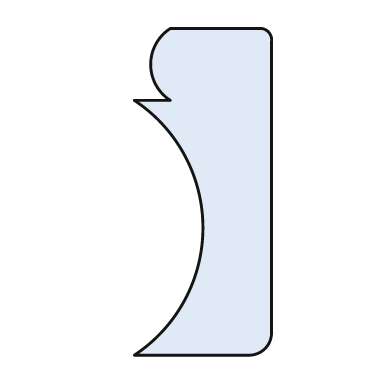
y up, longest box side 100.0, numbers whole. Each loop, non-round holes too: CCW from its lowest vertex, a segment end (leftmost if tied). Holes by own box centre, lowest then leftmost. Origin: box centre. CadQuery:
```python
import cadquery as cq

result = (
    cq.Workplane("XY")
    .moveTo(-21.0, -50.0)
    .lineTo(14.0, -50.0)
    .threePointArc((19.0, -48.0), (21.0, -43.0))
    .lineTo(21.0, 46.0)
    .threePointArc((20.0, 49.0), (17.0, 50.0))
    .lineTo(-10.0, 50.0)
    .threePointArc((-16.0, 39.0), (-10.0, 28.0))
    .lineTo(-21.0, 28.0)
    .threePointArc((0.0, -11.0), (-21.0, -50.0))
    .close()
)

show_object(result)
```